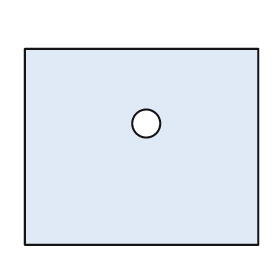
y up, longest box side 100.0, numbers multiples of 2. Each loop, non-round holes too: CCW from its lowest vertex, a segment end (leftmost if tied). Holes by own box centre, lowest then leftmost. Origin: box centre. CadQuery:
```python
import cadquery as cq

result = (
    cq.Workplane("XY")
    .moveTo(-50.0, -42.0)
    .lineTo(50.0, -42.0)
    .lineTo(50.0, 42.0)
    .lineTo(-50.0, 42.0)
    .close()
    .moveTo(2.0, 10.0)
    .circle(6.0)
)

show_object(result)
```